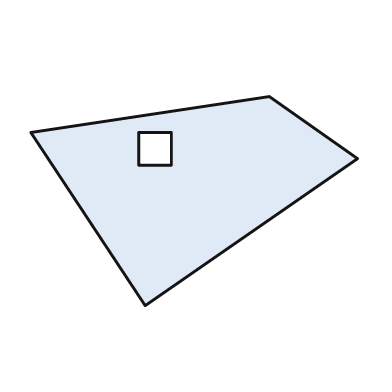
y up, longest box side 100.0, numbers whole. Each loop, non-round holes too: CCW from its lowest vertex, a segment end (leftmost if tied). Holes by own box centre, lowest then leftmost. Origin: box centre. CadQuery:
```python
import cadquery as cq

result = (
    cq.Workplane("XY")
    .moveTo(-15.0, -32.0)
    .lineTo(50.0, 13.0)
    .lineTo(23.0, 32.0)
    .lineTo(-50.0, 21.0)
    .close()
    .moveTo(-17.0, 11.0)
    .lineTo(-7.0, 11.0)
    .lineTo(-7.0, 21.0)
    .lineTo(-17.0, 21.0)
    .close()
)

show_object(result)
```